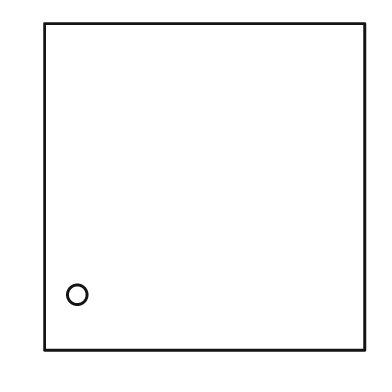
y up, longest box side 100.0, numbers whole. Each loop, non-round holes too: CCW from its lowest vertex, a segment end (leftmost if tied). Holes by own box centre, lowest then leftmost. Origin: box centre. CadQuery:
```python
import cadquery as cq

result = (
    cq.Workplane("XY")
    .moveTo(-49.0, -50.0)
    .lineTo(49.0, -50.0)
    .lineTo(49.0, 50.0)
    .lineTo(-49.0, 50.0)
    .close()
    .moveTo(-39.0, -33.0)
    .circle(3.0)
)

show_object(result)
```